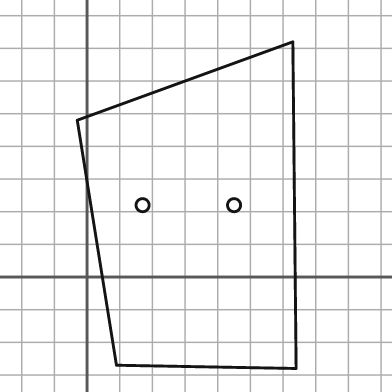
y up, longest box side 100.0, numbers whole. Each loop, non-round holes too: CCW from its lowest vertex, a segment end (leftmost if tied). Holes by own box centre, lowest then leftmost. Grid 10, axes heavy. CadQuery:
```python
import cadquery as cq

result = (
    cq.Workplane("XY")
    .moveTo(64.0, -28.0)
    .lineTo(63.0, 72.0)
    .lineTo(-3.0, 48.0)
    .lineTo(9.0, -27.0)
    .close()
    .moveTo(17.0, 22.0)
    .circle(2.0)
    .moveTo(45.0, 22.0)
    .circle(2.0)
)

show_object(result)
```